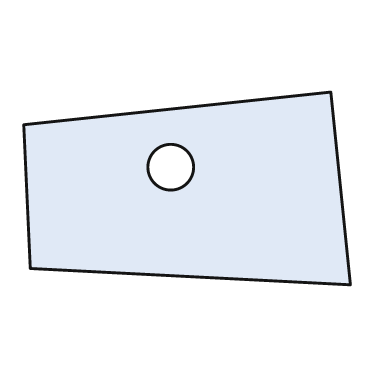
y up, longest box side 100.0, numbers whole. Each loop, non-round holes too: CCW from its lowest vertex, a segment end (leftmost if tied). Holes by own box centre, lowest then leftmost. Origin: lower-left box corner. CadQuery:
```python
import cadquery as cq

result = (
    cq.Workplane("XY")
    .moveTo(100.0, 0.0)
    .lineTo(94.0, 59.0)
    .lineTo(0.0, 49.0)
    .lineTo(2.0, 5.0)
    .close()
    .moveTo(45.0, 36.0)
    .circle(7.0)
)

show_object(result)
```